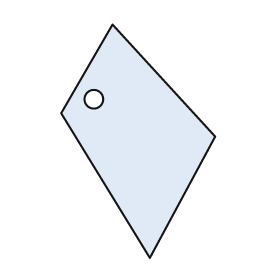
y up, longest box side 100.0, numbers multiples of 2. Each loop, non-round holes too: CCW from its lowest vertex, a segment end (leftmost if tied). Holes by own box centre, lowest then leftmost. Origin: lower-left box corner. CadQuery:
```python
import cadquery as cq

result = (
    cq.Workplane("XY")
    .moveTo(38.0, 0.0)
    .lineTo(66.0, 52.0)
    .lineTo(22.0, 100.0)
    .lineTo(0.0, 62.0)
    .close()
    .moveTo(14.0, 68.0)
    .circle(4.0)
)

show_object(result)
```